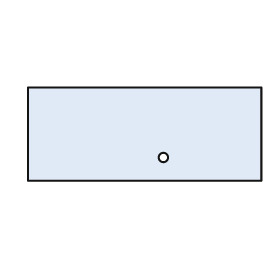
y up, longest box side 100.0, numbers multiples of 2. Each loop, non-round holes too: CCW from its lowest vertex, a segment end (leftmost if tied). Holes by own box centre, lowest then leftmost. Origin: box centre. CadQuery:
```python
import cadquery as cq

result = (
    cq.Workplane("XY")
    .moveTo(-50.0, -20.0)
    .lineTo(50.0, -20.0)
    .lineTo(50.0, 20.0)
    .lineTo(-50.0, 20.0)
    .close()
    .moveTo(8.0, -10.0)
    .circle(2.0)
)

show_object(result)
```